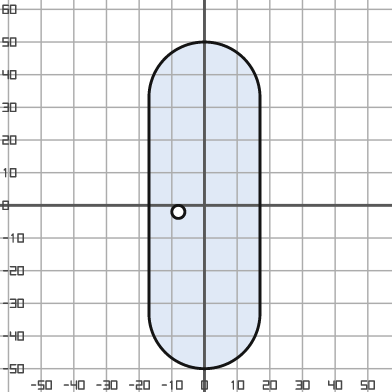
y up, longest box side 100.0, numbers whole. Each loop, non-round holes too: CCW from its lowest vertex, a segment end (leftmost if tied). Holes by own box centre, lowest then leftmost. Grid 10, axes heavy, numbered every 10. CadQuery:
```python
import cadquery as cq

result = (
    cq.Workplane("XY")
    .moveTo(-17.0, -33.0)
    .threePointArc((0.0, -50.0), (17.0, -33.0))
    .lineTo(17.0, 33.0)
    .threePointArc((0.0, 50.0), (-17.0, 33.0))
    .close()
    .moveTo(-8.0, -2.0)
    .circle(2.0)
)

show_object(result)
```